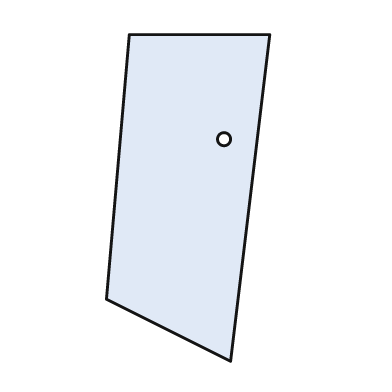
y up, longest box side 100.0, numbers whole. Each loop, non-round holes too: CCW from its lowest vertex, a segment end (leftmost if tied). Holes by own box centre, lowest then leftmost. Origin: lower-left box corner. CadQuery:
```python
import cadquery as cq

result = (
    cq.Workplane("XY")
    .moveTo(38.0, 0.0)
    .lineTo(50.0, 100.0)
    .lineTo(7.0, 100.0)
    .lineTo(0.0, 19.0)
    .close()
    .moveTo(36.0, 68.0)
    .circle(2.0)
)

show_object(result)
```